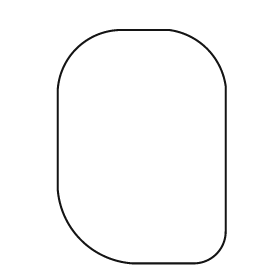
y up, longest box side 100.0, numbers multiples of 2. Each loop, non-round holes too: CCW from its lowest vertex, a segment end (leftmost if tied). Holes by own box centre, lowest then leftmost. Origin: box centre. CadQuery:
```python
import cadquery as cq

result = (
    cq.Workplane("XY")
    .moveTo(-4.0, -50.0)
    .lineTo(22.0, -50.0)
    .threePointArc((32.0, -46.0), (36.0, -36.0))
    .lineTo(36.0, 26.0)
    .threePointArc((28.0, 42.0), (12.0, 50.0))
    .lineTo(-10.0, 50.0)
    .threePointArc((-28.0, 42.0), (-36.0, 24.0))
    .lineTo(-36.0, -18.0)
    .threePointArc((-26.0, -40.0), (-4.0, -50.0))
    .close()
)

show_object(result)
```